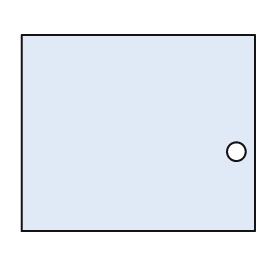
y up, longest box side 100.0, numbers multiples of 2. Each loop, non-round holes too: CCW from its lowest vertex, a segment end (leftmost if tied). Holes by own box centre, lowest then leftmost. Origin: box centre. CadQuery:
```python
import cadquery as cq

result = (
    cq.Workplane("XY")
    .moveTo(-50.0, -42.0)
    .lineTo(50.0, -42.0)
    .lineTo(50.0, 42.0)
    .lineTo(-50.0, 42.0)
    .close()
    .moveTo(42.0, -8.0)
    .circle(4.0)
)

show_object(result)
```